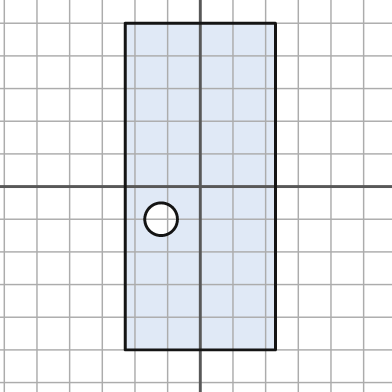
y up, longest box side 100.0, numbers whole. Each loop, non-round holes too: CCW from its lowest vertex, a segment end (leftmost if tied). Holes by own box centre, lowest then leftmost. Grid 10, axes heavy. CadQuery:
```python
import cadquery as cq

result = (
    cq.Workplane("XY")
    .moveTo(-23.0, -50.0)
    .lineTo(23.0, -50.0)
    .lineTo(23.0, 50.0)
    .lineTo(-23.0, 50.0)
    .close()
    .moveTo(-12.0, -10.0)
    .circle(5.0)
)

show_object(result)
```